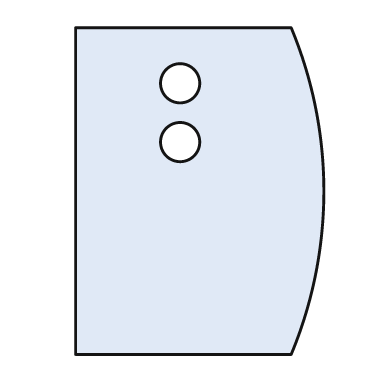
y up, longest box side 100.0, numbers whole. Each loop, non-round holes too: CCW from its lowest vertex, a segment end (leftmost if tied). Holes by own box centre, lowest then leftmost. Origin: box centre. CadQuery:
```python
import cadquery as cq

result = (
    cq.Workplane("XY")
    .moveTo(-38.0, -50.0)
    .lineTo(28.0, -50.0)
    .threePointArc((38.0, 0.0), (28.0, 50.0))
    .lineTo(-38.0, 50.0)
    .close()
    .moveTo(-6.0, 15.0)
    .circle(6.0)
    .moveTo(-6.0, 33.0)
    .circle(6.0)
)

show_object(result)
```